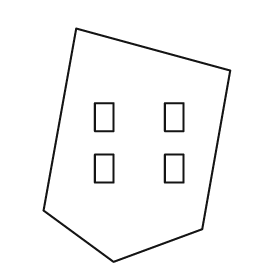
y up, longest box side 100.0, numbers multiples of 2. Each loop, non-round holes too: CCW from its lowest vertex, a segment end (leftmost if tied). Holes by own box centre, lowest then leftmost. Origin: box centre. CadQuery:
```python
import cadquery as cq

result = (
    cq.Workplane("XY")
    .moveTo(-10.0, -50.0)
    .lineTo(28.0, -36.0)
    .lineTo(40.0, 32.0)
    .lineTo(-26.0, 50.0)
    .lineTo(-40.0, -28.0)
    .close()
    .moveTo(-18.0, -16.0)
    .lineTo(-10.0, -16.0)
    .lineTo(-10.0, -4.0)
    .lineTo(-18.0, -4.0)
    .close()
    .moveTo(12.0, -16.0)
    .lineTo(20.0, -16.0)
    .lineTo(20.0, -4.0)
    .lineTo(12.0, -4.0)
    .close()
    .moveTo(-18.0, 6.0)
    .lineTo(-10.0, 6.0)
    .lineTo(-10.0, 18.0)
    .lineTo(-18.0, 18.0)
    .close()
    .moveTo(12.0, 6.0)
    .lineTo(20.0, 6.0)
    .lineTo(20.0, 18.0)
    .lineTo(12.0, 18.0)
    .close()
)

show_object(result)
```